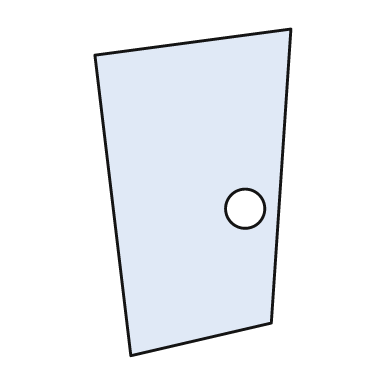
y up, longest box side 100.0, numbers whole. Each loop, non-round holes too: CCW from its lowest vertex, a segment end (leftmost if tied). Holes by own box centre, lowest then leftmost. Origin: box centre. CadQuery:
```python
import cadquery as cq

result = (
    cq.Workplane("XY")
    .moveTo(-19.0, -50.0)
    .lineTo(24.0, -40.0)
    .lineTo(30.0, 50.0)
    .lineTo(-30.0, 42.0)
    .close()
    .moveTo(16.0, -5.0)
    .circle(6.0)
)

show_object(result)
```